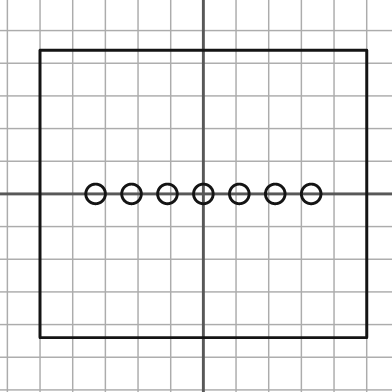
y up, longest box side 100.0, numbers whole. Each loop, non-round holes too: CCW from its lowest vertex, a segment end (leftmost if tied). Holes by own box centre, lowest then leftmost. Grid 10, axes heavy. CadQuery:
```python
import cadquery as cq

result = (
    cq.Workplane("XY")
    .moveTo(-50.0, -44.0)
    .lineTo(50.0, -44.0)
    .lineTo(50.0, 44.0)
    .lineTo(-50.0, 44.0)
    .close()
    .moveTo(-33.0, 0.0)
    .circle(3.0)
    .moveTo(-22.0, 0.0)
    .circle(3.0)
    .moveTo(-11.0, 0.0)
    .circle(3.0)
    .moveTo(0.0, 0.0)
    .circle(3.0)
    .moveTo(11.0, 0.0)
    .circle(3.0)
    .moveTo(22.0, 0.0)
    .circle(3.0)
    .moveTo(33.0, 0.0)
    .circle(3.0)
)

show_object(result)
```